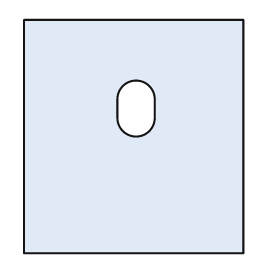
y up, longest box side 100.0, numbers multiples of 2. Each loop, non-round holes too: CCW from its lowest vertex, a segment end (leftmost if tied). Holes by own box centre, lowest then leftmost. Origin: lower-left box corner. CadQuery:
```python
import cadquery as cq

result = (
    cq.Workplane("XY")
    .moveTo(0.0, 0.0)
    .lineTo(94.0, 0.0)
    .lineTo(94.0, 100.0)
    .lineTo(0.0, 100.0)
    .close()
    .moveTo(40.0, 58.0)
    .threePointArc((48.0, 50.0), (56.0, 58.0))
    .lineTo(56.0, 66.0)
    .threePointArc((48.0, 74.0), (40.0, 66.0))
    .close()
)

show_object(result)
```